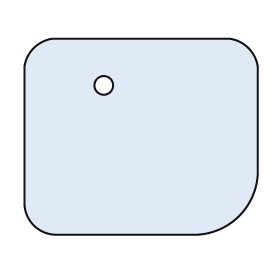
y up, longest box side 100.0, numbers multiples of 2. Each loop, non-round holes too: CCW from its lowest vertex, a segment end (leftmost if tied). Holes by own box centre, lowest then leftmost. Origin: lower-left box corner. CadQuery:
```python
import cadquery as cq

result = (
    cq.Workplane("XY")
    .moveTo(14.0, 0.0)
    .lineTo(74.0, 0.0)
    .threePointArc((92.0, 8.0), (100.0, 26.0))
    .lineTo(100.0, 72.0)
    .threePointArc((96.0, 80.0), (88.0, 84.0))
    .lineTo(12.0, 84.0)
    .threePointArc((4.0, 80.0), (0.0, 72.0))
    .lineTo(0.0, 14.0)
    .threePointArc((4.0, 4.0), (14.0, 0.0))
    .close()
    .moveTo(34.0, 64.0)
    .circle(4.0)
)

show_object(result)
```